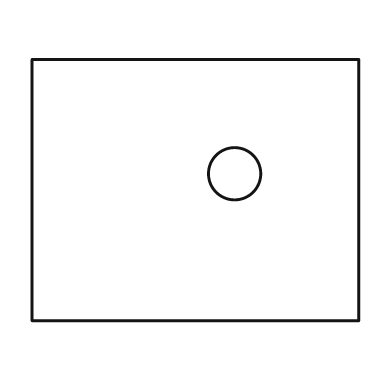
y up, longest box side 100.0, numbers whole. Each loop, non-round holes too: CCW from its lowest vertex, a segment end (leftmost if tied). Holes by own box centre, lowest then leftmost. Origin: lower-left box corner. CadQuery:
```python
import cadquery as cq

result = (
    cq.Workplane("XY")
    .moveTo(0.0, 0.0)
    .lineTo(100.0, 0.0)
    .lineTo(100.0, 80.0)
    .lineTo(0.0, 80.0)
    .close()
    .moveTo(62.0, 45.0)
    .circle(8.0)
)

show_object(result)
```